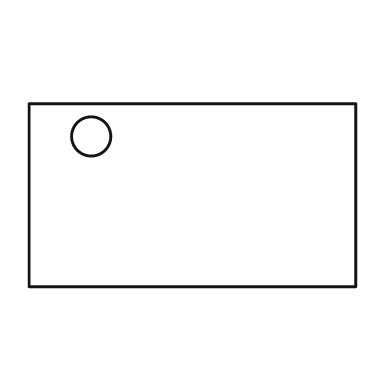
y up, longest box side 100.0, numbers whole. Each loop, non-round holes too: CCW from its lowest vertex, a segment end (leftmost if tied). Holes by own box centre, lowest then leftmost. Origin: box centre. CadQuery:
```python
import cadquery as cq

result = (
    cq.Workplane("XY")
    .moveTo(-50.0, -28.0)
    .lineTo(50.0, -28.0)
    .lineTo(50.0, 28.0)
    .lineTo(-50.0, 28.0)
    .close()
    .moveTo(-31.0, 18.0)
    .circle(6.0)
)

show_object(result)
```